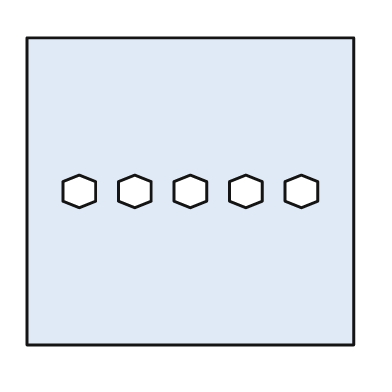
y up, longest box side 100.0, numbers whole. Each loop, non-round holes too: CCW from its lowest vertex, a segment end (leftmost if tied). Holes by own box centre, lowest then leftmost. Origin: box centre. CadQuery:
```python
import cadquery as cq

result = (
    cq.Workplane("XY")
    .moveTo(-50.0, -47.0)
    .lineTo(50.0, -47.0)
    .lineTo(50.0, 47.0)
    .lineTo(-50.0, 47.0)
    .close()
    .moveTo(-34.0, -5.0)
    .lineTo(-29.0, -3.0)
    .lineTo(-29.0, 3.0)
    .lineTo(-34.0, 5.0)
    .lineTo(-39.0, 3.0)
    .lineTo(-39.0, -3.0)
    .close()
    .moveTo(-17.0, -5.0)
    .lineTo(-12.0, -3.0)
    .lineTo(-12.0, 3.0)
    .lineTo(-17.0, 5.0)
    .lineTo(-22.0, 3.0)
    .lineTo(-22.0, -3.0)
    .close()
    .moveTo(0.0, -5.0)
    .lineTo(5.0, -3.0)
    .lineTo(5.0, 3.0)
    .lineTo(0.0, 5.0)
    .lineTo(-5.0, 3.0)
    .lineTo(-5.0, -3.0)
    .close()
    .moveTo(17.0, -5.0)
    .lineTo(22.0, -3.0)
    .lineTo(22.0, 3.0)
    .lineTo(17.0, 5.0)
    .lineTo(12.0, 3.0)
    .lineTo(12.0, -3.0)
    .close()
    .moveTo(34.0, -5.0)
    .lineTo(39.0, -3.0)
    .lineTo(39.0, 3.0)
    .lineTo(34.0, 5.0)
    .lineTo(29.0, 3.0)
    .lineTo(29.0, -3.0)
    .close()
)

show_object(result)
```